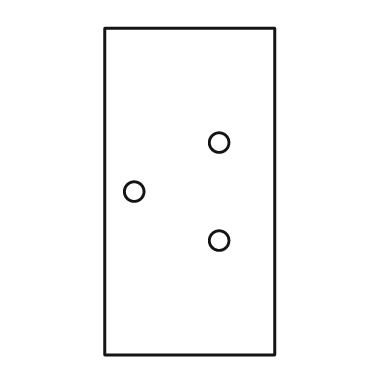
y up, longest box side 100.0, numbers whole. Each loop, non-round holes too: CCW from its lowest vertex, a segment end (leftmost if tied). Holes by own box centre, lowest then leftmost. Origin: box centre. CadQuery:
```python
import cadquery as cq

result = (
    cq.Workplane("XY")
    .moveTo(-26.0, -50.0)
    .lineTo(26.0, -50.0)
    .lineTo(26.0, 50.0)
    .lineTo(-26.0, 50.0)
    .close()
    .moveTo(9.0, -15.0)
    .circle(3.0)
    .moveTo(-17.0, 0.0)
    .circle(3.0)
    .moveTo(9.0, 15.0)
    .circle(3.0)
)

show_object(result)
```